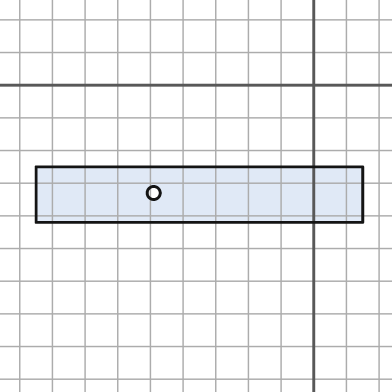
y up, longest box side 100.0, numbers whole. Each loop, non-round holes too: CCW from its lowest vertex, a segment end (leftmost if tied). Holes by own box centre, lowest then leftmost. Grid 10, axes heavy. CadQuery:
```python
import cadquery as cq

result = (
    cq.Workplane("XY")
    .moveTo(-85.0, -42.0)
    .lineTo(15.0, -42.0)
    .lineTo(15.0, -25.0)
    .lineTo(-85.0, -25.0)
    .close()
    .moveTo(-49.0, -33.0)
    .circle(2.0)
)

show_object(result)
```